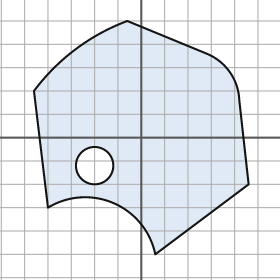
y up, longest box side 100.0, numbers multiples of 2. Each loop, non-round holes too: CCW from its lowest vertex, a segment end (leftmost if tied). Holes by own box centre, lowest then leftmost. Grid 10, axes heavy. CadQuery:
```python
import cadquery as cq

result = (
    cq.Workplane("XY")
    .moveTo(6.0, -50.0)
    .lineTo(46.0, -20.0)
    .lineTo(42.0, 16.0)
    .threePointArc((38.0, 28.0), (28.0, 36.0))
    .lineTo(-6.0, 50.0)
    .threePointArc((-28.0, 38.0), (-46.0, 20.0))
    .lineTo(-40.0, -30.0)
    .threePointArc((-12.0, -28.0), (6.0, -50.0))
    .close()
    .moveTo(-20.0, -12.0)
    .circle(8.0)
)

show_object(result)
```